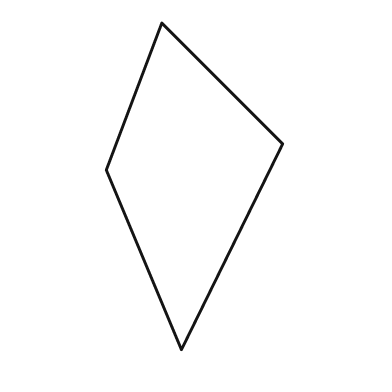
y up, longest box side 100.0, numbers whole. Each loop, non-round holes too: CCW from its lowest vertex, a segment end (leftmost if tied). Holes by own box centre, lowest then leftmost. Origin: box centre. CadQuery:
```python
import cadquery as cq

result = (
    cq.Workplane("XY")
    .moveTo(-4.0, -50.0)
    .lineTo(27.0, 13.0)
    .lineTo(-10.0, 50.0)
    .lineTo(-27.0, 5.0)
    .close()
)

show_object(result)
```